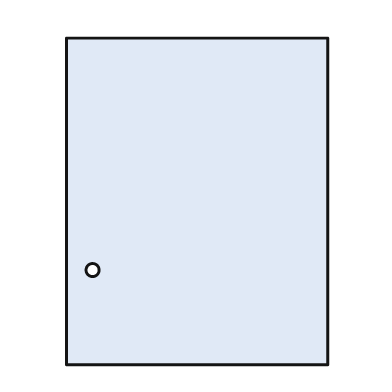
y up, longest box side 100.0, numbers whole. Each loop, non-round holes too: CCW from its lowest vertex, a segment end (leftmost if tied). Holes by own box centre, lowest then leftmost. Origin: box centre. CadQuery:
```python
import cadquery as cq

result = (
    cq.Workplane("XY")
    .moveTo(-40.0, -50.0)
    .lineTo(40.0, -50.0)
    .lineTo(40.0, 50.0)
    .lineTo(-40.0, 50.0)
    .close()
    .moveTo(-32.0, -21.0)
    .circle(2.0)
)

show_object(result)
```